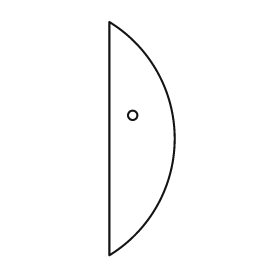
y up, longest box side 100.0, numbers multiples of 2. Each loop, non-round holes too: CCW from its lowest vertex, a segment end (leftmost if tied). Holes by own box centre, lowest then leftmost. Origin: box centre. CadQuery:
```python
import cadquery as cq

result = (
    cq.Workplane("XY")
    .moveTo(-14.0, -50.0)
    .threePointArc((14.0, 0.0), (-14.0, 50.0))
    .close()
    .moveTo(-4.0, 10.0)
    .circle(2.0)
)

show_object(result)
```